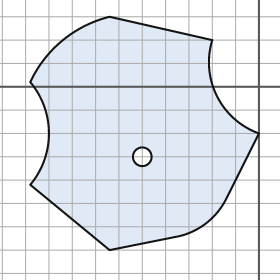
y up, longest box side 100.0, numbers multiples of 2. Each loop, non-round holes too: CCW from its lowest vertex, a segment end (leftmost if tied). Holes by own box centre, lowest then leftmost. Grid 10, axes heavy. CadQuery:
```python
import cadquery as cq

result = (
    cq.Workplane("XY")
    .moveTo(-64.0, -70.0)
    .lineTo(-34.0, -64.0)
    .threePointArc((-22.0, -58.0), (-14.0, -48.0))
    .lineTo(0.0, -20.0)
    .threePointArc((-18.0, -4.0), (-20.0, 20.0))
    .lineTo(-64.0, 30.0)
    .threePointArc((-84.0, 20.0), (-98.0, 2.0))
    .threePointArc((-90.0, -20.0), (-98.0, -42.0))
    .close()
    .moveTo(-50.0, -30.0)
    .circle(4.0)
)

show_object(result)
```